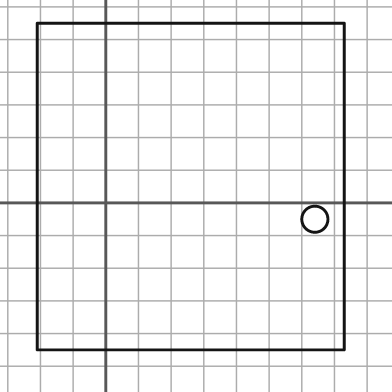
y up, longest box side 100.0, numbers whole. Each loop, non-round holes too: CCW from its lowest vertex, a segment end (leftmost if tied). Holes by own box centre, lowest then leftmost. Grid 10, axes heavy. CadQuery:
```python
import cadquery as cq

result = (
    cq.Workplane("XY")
    .moveTo(-21.0, -45.0)
    .lineTo(73.0, -45.0)
    .lineTo(73.0, 55.0)
    .lineTo(-21.0, 55.0)
    .close()
    .moveTo(64.0, -5.0)
    .circle(4.0)
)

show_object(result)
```